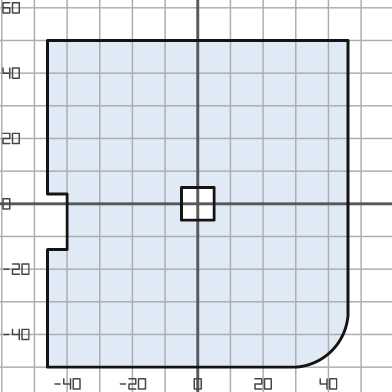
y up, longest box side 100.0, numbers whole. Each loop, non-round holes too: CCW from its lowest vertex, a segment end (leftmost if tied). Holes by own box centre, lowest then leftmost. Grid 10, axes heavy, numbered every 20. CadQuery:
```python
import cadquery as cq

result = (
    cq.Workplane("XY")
    .moveTo(-46.0, -50.0)
    .lineTo(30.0, -50.0)
    .threePointArc((41.0, -45.0), (46.0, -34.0))
    .lineTo(46.0, 50.0)
    .lineTo(-46.0, 50.0)
    .lineTo(-46.0, 3.0)
    .lineTo(-40.0, 3.0)
    .lineTo(-40.0, -14.0)
    .lineTo(-46.0, -14.0)
    .close()
    .moveTo(-5.0, -5.0)
    .lineTo(5.0, -5.0)
    .lineTo(5.0, 5.0)
    .lineTo(-5.0, 5.0)
    .close()
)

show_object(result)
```